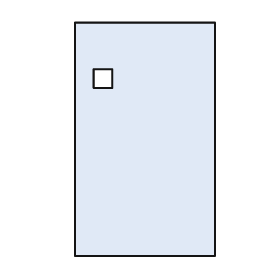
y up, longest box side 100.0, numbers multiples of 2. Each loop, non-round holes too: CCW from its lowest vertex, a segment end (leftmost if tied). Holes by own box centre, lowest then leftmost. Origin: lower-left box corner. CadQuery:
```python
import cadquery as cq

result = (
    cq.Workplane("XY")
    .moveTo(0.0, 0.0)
    .lineTo(60.0, 0.0)
    .lineTo(60.0, 100.0)
    .lineTo(0.0, 100.0)
    .close()
    .moveTo(8.0, 72.0)
    .lineTo(16.0, 72.0)
    .lineTo(16.0, 80.0)
    .lineTo(8.0, 80.0)
    .close()
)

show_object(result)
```